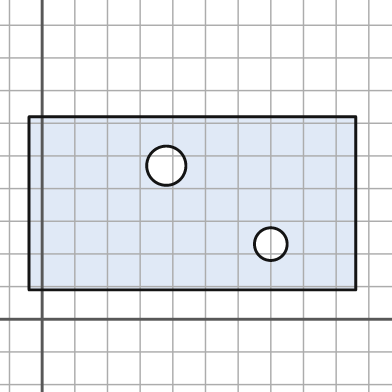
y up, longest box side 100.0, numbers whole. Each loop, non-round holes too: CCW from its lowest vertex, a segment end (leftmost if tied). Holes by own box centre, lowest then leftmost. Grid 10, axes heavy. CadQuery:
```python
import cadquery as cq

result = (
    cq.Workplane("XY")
    .moveTo(-4.0, 9.0)
    .lineTo(96.0, 9.0)
    .lineTo(96.0, 62.0)
    .lineTo(-4.0, 62.0)
    .close()
    .moveTo(70.0, 23.0)
    .circle(5.0)
    .moveTo(38.0, 47.0)
    .circle(6.0)
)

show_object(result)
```